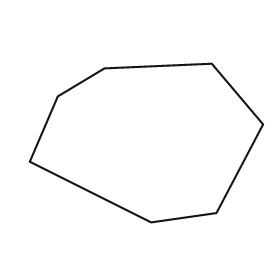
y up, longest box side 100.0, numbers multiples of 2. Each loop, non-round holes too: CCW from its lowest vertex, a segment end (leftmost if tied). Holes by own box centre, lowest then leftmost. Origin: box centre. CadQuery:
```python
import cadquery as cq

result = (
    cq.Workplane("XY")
    .moveTo(2.0, -34.0)
    .lineTo(30.0, -30.0)
    .lineTo(50.0, 8.0)
    .lineTo(28.0, 34.0)
    .lineTo(-18.0, 32.0)
    .lineTo(-38.0, 20.0)
    .lineTo(-50.0, -8.0)
    .close()
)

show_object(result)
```